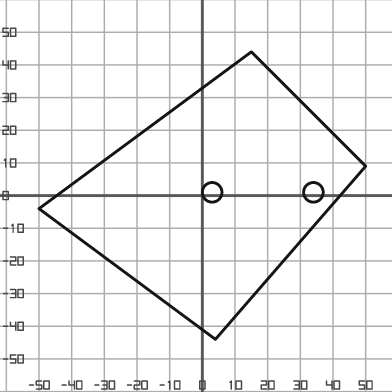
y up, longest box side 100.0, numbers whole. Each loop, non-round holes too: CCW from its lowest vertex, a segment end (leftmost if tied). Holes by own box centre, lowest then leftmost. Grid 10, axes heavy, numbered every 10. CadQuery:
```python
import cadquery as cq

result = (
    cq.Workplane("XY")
    .moveTo(4.0, -44.0)
    .lineTo(50.0, 9.0)
    .lineTo(15.0, 44.0)
    .lineTo(-50.0, -4.0)
    .close()
    .moveTo(3.0, 1.0)
    .circle(3.0)
    .moveTo(34.0, 1.0)
    .circle(3.0)
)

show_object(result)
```